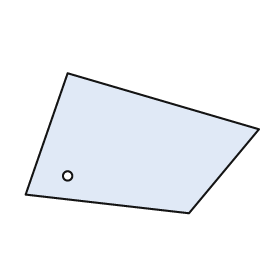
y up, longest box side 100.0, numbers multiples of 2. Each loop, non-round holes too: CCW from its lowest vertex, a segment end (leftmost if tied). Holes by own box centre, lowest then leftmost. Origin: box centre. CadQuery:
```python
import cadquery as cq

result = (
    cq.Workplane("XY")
    .moveTo(20.0, -30.0)
    .lineTo(50.0, 6.0)
    .lineTo(-32.0, 30.0)
    .lineTo(-50.0, -22.0)
    .close()
    .moveTo(-32.0, -14.0)
    .circle(2.0)
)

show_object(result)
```